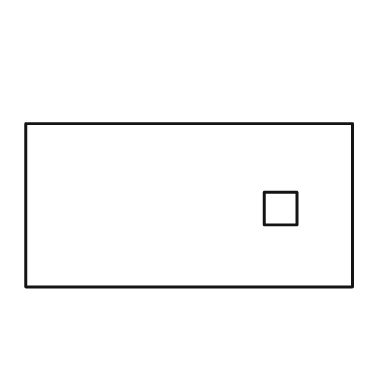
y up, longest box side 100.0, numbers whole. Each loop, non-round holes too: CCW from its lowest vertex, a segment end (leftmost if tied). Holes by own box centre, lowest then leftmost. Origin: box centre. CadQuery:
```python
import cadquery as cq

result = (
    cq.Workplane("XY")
    .moveTo(-50.0, -25.0)
    .lineTo(50.0, -25.0)
    .lineTo(50.0, 25.0)
    .lineTo(-50.0, 25.0)
    .close()
    .moveTo(23.0, -6.0)
    .lineTo(33.0, -6.0)
    .lineTo(33.0, 4.0)
    .lineTo(23.0, 4.0)
    .close()
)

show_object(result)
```